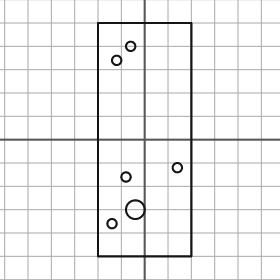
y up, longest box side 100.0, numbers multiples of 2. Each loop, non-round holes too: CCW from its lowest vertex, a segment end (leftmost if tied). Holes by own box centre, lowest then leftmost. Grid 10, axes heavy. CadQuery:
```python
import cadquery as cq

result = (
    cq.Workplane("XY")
    .moveTo(-20.0, -50.0)
    .lineTo(20.0, -50.0)
    .lineTo(20.0, 50.0)
    .lineTo(-20.0, 50.0)
    .close()
    .moveTo(-14.0, -36.0)
    .circle(2.0)
    .moveTo(-4.0, -30.0)
    .circle(4.0)
    .moveTo(-8.0, -16.0)
    .circle(2.0)
    .moveTo(14.0, -12.0)
    .circle(2.0)
    .moveTo(-12.0, 34.0)
    .circle(2.0)
    .moveTo(-6.0, 40.0)
    .circle(2.0)
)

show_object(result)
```